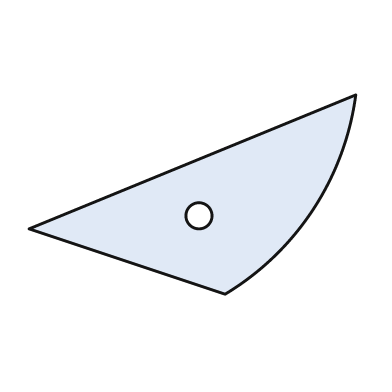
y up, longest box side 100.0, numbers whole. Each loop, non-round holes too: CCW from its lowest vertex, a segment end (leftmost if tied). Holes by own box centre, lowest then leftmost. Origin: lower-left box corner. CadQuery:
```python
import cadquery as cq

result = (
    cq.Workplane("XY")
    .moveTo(60.0, 0.0)
    .threePointArc((87.0, 26.0), (100.0, 61.0))
    .lineTo(0.0, 20.0)
    .close()
    .moveTo(52.0, 24.0)
    .circle(4.0)
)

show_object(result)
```